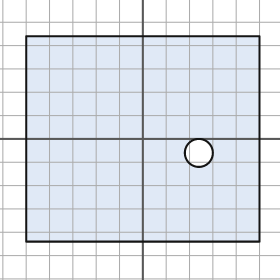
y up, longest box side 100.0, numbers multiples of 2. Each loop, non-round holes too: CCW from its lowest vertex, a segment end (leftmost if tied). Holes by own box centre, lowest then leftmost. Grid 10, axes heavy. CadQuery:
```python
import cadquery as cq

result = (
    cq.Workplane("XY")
    .moveTo(-50.0, -44.0)
    .lineTo(50.0, -44.0)
    .lineTo(50.0, 44.0)
    .lineTo(-50.0, 44.0)
    .close()
    .moveTo(24.0, -6.0)
    .circle(6.0)
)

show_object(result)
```